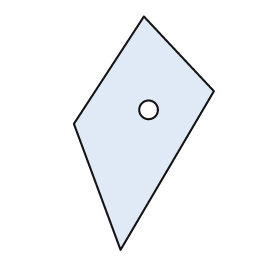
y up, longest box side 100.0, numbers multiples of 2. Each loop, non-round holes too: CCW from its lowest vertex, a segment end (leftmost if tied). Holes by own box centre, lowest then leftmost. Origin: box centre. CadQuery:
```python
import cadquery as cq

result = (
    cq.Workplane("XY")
    .moveTo(-10.0, -50.0)
    .lineTo(30.0, 18.0)
    .lineTo(0.0, 50.0)
    .lineTo(-30.0, 4.0)
    .close()
    .moveTo(2.0, 10.0)
    .circle(4.0)
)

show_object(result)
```